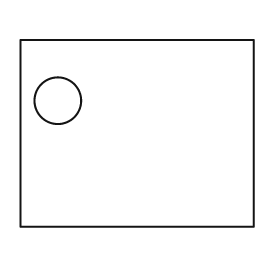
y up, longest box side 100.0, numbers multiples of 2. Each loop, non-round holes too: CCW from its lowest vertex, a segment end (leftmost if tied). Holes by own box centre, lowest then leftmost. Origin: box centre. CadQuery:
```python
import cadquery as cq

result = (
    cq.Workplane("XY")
    .moveTo(-50.0, -40.0)
    .lineTo(50.0, -40.0)
    .lineTo(50.0, 40.0)
    .lineTo(-50.0, 40.0)
    .close()
    .moveTo(-34.0, 14.0)
    .circle(10.0)
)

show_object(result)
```